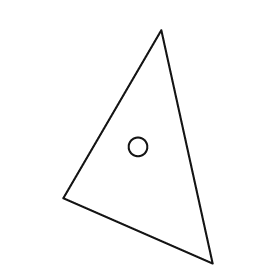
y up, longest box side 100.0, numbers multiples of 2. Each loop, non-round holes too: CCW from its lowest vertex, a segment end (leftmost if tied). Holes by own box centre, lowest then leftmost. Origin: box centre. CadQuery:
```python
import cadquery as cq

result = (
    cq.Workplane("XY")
    .moveTo(32.0, -50.0)
    .lineTo(10.0, 50.0)
    .lineTo(-32.0, -22.0)
    .close()
    .moveTo(0.0, 0.0)
    .circle(4.0)
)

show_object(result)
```